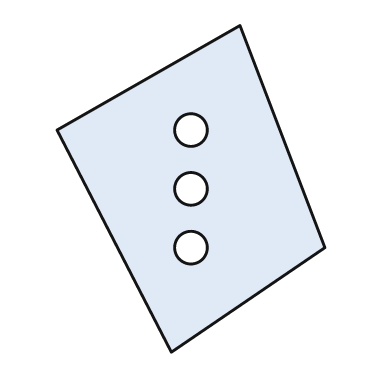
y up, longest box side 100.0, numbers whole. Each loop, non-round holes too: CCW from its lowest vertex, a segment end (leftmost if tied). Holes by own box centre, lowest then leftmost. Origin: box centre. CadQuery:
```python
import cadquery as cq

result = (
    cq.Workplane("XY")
    .moveTo(-6.0, -50.0)
    .lineTo(41.0, -18.0)
    .lineTo(15.0, 50.0)
    .lineTo(-41.0, 18.0)
    .close()
    .moveTo(0.0, -18.0)
    .circle(5.0)
    .moveTo(0.0, 0.0)
    .circle(5.0)
    .moveTo(0.0, 18.0)
    .circle(5.0)
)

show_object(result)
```